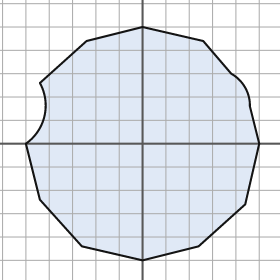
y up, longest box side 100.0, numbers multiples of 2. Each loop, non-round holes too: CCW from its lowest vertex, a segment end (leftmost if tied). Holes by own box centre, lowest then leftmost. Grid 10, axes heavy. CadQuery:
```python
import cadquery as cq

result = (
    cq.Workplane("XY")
    .moveTo(0.0, -50.0)
    .lineTo(24.0, -44.0)
    .lineTo(44.0, -26.0)
    .lineTo(50.0, 0.0)
    .lineTo(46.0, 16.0)
    .threePointArc((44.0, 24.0), (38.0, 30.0))
    .lineTo(26.0, 44.0)
    .lineTo(0.0, 50.0)
    .lineTo(-24.0, 44.0)
    .lineTo(-44.0, 26.0)
    .threePointArc((-42.0, 12.0), (-50.0, 0.0))
    .lineTo(-44.0, -24.0)
    .lineTo(-26.0, -44.0)
    .close()
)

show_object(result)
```